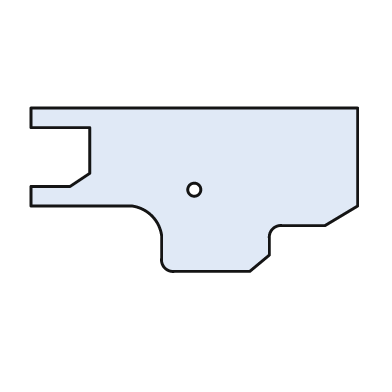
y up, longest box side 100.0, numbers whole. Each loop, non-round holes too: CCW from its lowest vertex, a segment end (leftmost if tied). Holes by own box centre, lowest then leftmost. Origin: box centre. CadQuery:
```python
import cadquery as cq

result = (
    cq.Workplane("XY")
    .moveTo(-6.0, -25.0)
    .lineTo(17.0, -25.0)
    .lineTo(23.0, -20.0)
    .lineTo(23.0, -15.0)
    .threePointArc((24.0, -12.0), (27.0, -11.0))
    .lineTo(40.0, -11.0)
    .lineTo(50.0, -5.0)
    .lineTo(50.0, 25.0)
    .lineTo(-50.0, 25.0)
    .lineTo(-50.0, 19.0)
    .lineTo(-32.0, 19.0)
    .lineTo(-32.0, 5.0)
    .lineTo(-38.0, 1.0)
    .lineTo(-50.0, 1.0)
    .lineTo(-50.0, -5.0)
    .lineTo(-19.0, -5.0)
    .threePointArc((-13.0, -8.0), (-10.0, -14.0))
    .lineTo(-10.0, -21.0)
    .threePointArc((-9.0, -24.0), (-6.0, -25.0))
    .close()
    .moveTo(0.0, 0.0)
    .circle(2.0)
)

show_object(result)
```